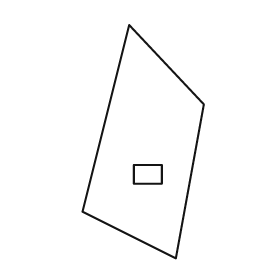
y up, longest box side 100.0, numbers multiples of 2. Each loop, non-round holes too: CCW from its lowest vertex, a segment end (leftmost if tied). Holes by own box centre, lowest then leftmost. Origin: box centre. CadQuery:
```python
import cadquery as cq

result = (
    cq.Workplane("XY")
    .moveTo(14.0, -50.0)
    .lineTo(26.0, 16.0)
    .lineTo(-6.0, 50.0)
    .lineTo(-26.0, -30.0)
    .close()
    .moveTo(-4.0, -18.0)
    .lineTo(8.0, -18.0)
    .lineTo(8.0, -10.0)
    .lineTo(-4.0, -10.0)
    .close()
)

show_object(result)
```